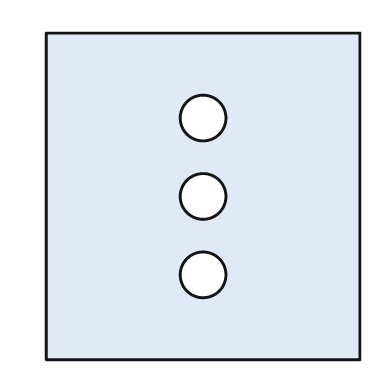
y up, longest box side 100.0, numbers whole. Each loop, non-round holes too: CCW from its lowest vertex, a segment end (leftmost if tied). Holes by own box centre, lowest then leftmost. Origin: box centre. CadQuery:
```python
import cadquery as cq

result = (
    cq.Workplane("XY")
    .moveTo(-48.0, -50.0)
    .lineTo(48.0, -50.0)
    .lineTo(48.0, 50.0)
    .lineTo(-48.0, 50.0)
    .close()
    .moveTo(0.0, -24.0)
    .circle(7.0)
    .moveTo(0.0, 0.0)
    .circle(7.0)
    .moveTo(0.0, 24.0)
    .circle(7.0)
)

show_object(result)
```